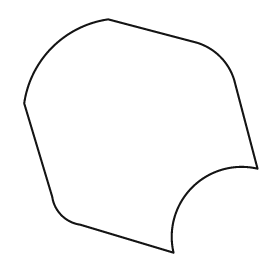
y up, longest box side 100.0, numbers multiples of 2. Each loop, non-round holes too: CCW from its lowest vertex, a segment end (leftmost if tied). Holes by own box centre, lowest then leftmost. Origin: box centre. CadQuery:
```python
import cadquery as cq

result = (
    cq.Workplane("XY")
    .moveTo(14.0, -50.0)
    .threePointArc((22.0, -22.0), (50.0, -14.0))
    .lineTo(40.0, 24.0)
    .threePointArc((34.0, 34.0), (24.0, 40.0))
    .lineTo(-14.0, 50.0)
    .threePointArc((-38.0, 38.0), (-50.0, 14.0))
    .lineTo(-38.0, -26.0)
    .threePointArc((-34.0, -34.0), (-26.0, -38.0))
    .close()
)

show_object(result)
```